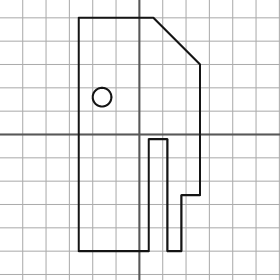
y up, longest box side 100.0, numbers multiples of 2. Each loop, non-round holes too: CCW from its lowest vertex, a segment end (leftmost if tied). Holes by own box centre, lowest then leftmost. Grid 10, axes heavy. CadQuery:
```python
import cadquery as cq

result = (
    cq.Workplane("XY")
    .moveTo(-26.0, -50.0)
    .lineTo(4.0, -50.0)
    .lineTo(4.0, -2.0)
    .lineTo(12.0, -2.0)
    .lineTo(12.0, -50.0)
    .lineTo(18.0, -50.0)
    .lineTo(18.0, -26.0)
    .lineTo(26.0, -26.0)
    .lineTo(26.0, 30.0)
    .lineTo(6.0, 50.0)
    .lineTo(-26.0, 50.0)
    .close()
    .moveTo(-16.0, 16.0)
    .circle(4.0)
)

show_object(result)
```